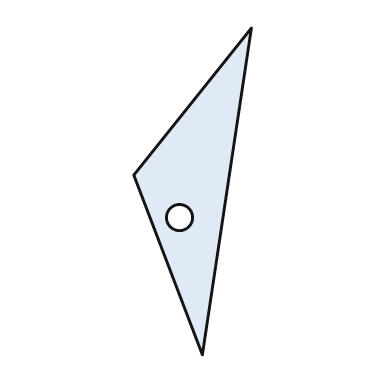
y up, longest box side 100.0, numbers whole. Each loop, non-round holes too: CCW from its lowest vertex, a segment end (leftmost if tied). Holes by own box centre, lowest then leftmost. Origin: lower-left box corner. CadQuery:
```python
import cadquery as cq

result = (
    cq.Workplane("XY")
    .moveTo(21.0, 0.0)
    .lineTo(36.0, 100.0)
    .lineTo(0.0, 55.0)
    .close()
    .moveTo(14.0, 42.0)
    .circle(4.0)
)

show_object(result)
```